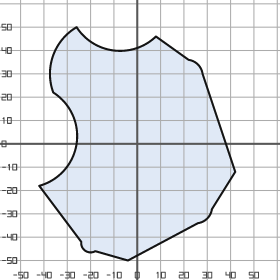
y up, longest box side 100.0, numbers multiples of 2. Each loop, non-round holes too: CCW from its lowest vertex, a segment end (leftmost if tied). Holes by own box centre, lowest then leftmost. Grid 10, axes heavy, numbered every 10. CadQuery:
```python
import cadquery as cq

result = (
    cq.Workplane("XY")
    .moveTo(-4.0, -50.0)
    .lineTo(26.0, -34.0)
    .threePointArc((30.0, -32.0), (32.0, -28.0))
    .lineTo(42.0, -12.0)
    .lineTo(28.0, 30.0)
    .threePointArc((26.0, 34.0), (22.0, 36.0))
    .lineTo(8.0, 46.0)
    .threePointArc((-10.0, 40.0), (-26.0, 50.0))
    .threePointArc((-36.0, 38.0), (-36.0, 22.0))
    .threePointArc((-26.0, 0.0), (-42.0, -18.0))
    .lineTo(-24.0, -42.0)
    .threePointArc((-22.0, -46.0), (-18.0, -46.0))
    .close()
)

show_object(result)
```